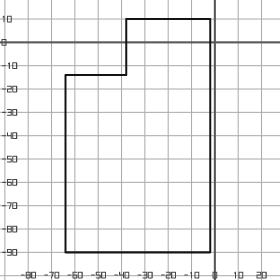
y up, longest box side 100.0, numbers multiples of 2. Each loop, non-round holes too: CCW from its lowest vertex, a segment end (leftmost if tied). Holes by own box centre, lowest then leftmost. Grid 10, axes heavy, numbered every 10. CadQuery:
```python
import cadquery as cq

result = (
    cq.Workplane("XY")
    .moveTo(-64.0, -90.0)
    .lineTo(-2.0, -90.0)
    .lineTo(-2.0, 10.0)
    .lineTo(-38.0, 10.0)
    .lineTo(-38.0, -14.0)
    .lineTo(-64.0, -14.0)
    .close()
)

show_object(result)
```